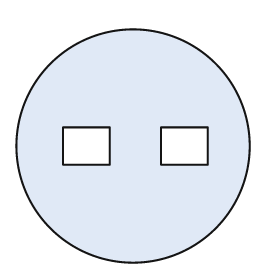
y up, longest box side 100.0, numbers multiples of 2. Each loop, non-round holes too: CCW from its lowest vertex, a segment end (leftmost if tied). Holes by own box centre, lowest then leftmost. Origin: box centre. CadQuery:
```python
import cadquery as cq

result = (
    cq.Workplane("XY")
    .moveTo(0.0, 0.0)
    .circle(50.0)
    .moveTo(-30.0, -8.0)
    .lineTo(-10.0, -8.0)
    .lineTo(-10.0, 8.0)
    .lineTo(-30.0, 8.0)
    .close()
    .moveTo(12.0, -8.0)
    .lineTo(32.0, -8.0)
    .lineTo(32.0, 8.0)
    .lineTo(12.0, 8.0)
    .close()
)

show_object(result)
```